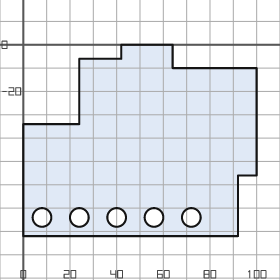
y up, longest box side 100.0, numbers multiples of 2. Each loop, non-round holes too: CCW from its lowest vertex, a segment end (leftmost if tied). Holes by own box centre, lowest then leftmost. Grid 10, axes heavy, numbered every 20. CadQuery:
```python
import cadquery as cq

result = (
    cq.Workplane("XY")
    .moveTo(0.0, -82.0)
    .lineTo(92.0, -82.0)
    .lineTo(92.0, -56.0)
    .lineTo(100.0, -56.0)
    .lineTo(100.0, -10.0)
    .lineTo(64.0, -10.0)
    .lineTo(64.0, 0.0)
    .lineTo(42.0, 0.0)
    .lineTo(42.0, -6.0)
    .lineTo(24.0, -6.0)
    .lineTo(24.0, -34.0)
    .lineTo(0.0, -34.0)
    .close()
    .moveTo(8.0, -74.0)
    .circle(4.0)
    .moveTo(24.0, -74.0)
    .circle(4.0)
    .moveTo(40.0, -74.0)
    .circle(4.0)
    .moveTo(56.0, -74.0)
    .circle(4.0)
    .moveTo(72.0, -74.0)
    .circle(4.0)
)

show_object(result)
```